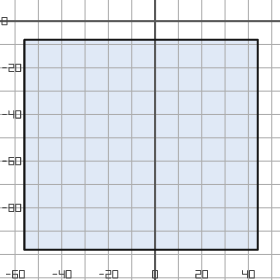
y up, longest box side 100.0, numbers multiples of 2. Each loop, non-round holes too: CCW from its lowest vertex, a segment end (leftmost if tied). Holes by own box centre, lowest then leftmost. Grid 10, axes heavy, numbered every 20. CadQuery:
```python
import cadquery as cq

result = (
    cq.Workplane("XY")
    .moveTo(-56.0, -98.0)
    .lineTo(44.0, -98.0)
    .lineTo(44.0, -8.0)
    .lineTo(-56.0, -8.0)
    .close()
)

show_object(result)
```